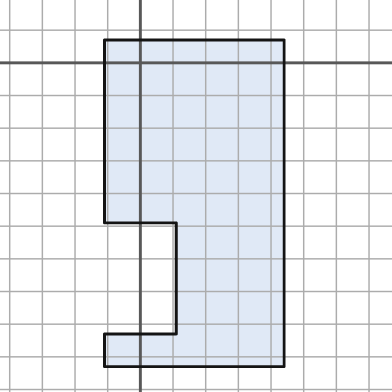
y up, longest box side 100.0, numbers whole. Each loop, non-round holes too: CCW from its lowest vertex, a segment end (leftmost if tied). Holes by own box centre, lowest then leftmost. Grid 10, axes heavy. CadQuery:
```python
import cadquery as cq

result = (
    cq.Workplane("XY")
    .moveTo(-11.0, -93.0)
    .lineTo(44.0, -93.0)
    .lineTo(44.0, 7.0)
    .lineTo(-11.0, 7.0)
    .lineTo(-11.0, -49.0)
    .lineTo(11.0, -49.0)
    .lineTo(11.0, -83.0)
    .lineTo(-11.0, -83.0)
    .close()
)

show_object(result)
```